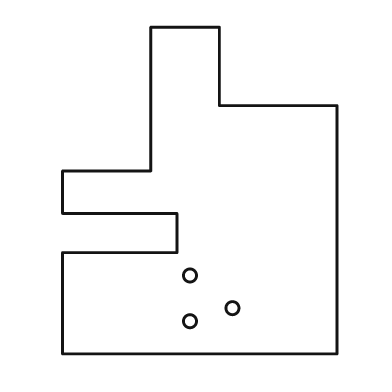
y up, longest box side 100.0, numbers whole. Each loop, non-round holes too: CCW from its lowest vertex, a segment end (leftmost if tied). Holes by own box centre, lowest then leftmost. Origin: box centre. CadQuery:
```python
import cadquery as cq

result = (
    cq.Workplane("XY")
    .moveTo(-42.0, -50.0)
    .lineTo(42.0, -50.0)
    .lineTo(42.0, 26.0)
    .lineTo(6.0, 26.0)
    .lineTo(6.0, 50.0)
    .lineTo(-15.0, 50.0)
    .lineTo(-15.0, 6.0)
    .lineTo(-42.0, 6.0)
    .lineTo(-42.0, -7.0)
    .lineTo(-7.0, -7.0)
    .lineTo(-7.0, -19.0)
    .lineTo(-42.0, -19.0)
    .close()
    .moveTo(-3.0, -40.0)
    .circle(2.0)
    .moveTo(10.0, -36.0)
    .circle(2.0)
    .moveTo(-3.0, -26.0)
    .circle(2.0)
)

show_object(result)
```